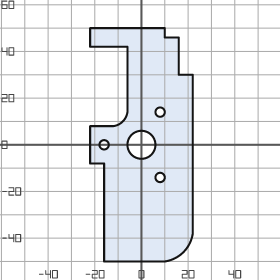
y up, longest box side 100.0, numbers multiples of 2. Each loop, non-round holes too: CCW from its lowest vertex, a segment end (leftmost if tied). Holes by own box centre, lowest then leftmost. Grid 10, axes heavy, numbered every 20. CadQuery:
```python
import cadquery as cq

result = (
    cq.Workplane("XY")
    .moveTo(-16.0, -50.0)
    .lineTo(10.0, -50.0)
    .threePointArc((18.0, -46.0), (22.0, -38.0))
    .lineTo(22.0, 30.0)
    .lineTo(16.0, 30.0)
    .lineTo(16.0, 46.0)
    .lineTo(10.0, 46.0)
    .lineTo(10.0, 50.0)
    .lineTo(-22.0, 50.0)
    .lineTo(-22.0, 42.0)
    .lineTo(-6.0, 42.0)
    .lineTo(-6.0, 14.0)
    .threePointArc((-8.0, 10.0), (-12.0, 8.0))
    .lineTo(-22.0, 8.0)
    .lineTo(-22.0, -8.0)
    .lineTo(-16.0, -8.0)
    .close()
    .moveTo(8.0, -14.0)
    .circle(2.0)
    .moveTo(-16.0, 0.0)
    .circle(2.0)
    .moveTo(0.0, 0.0)
    .circle(6.0)
    .moveTo(8.0, 14.0)
    .circle(2.0)
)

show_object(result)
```